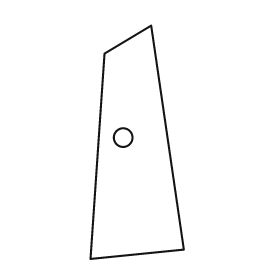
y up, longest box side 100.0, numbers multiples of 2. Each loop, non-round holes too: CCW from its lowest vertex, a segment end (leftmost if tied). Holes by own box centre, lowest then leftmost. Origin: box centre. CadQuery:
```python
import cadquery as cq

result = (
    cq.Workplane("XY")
    .moveTo(-20.0, -50.0)
    .lineTo(20.0, -46.0)
    .lineTo(6.0, 50.0)
    .lineTo(-14.0, 38.0)
    .close()
    .moveTo(-6.0, 2.0)
    .circle(4.0)
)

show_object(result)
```